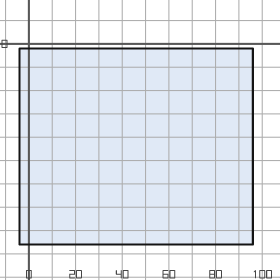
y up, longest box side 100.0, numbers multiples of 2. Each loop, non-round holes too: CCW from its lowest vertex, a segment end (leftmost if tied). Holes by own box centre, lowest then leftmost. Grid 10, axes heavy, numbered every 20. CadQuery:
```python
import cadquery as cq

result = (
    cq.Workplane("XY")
    .moveTo(-4.0, -86.0)
    .lineTo(96.0, -86.0)
    .lineTo(96.0, -2.0)
    .lineTo(-4.0, -2.0)
    .close()
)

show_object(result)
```